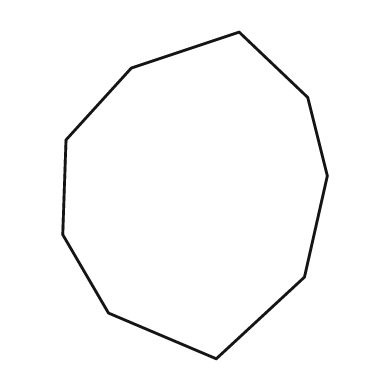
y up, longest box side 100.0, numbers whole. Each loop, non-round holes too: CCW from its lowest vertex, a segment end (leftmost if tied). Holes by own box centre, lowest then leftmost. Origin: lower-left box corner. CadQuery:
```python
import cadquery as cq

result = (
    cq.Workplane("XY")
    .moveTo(47.0, 0.0)
    .lineTo(74.0, 25.0)
    .lineTo(81.0, 56.0)
    .lineTo(75.0, 80.0)
    .lineTo(54.0, 100.0)
    .lineTo(21.0, 89.0)
    .lineTo(1.0, 67.0)
    .lineTo(0.0, 38.0)
    .lineTo(14.0, 14.0)
    .close()
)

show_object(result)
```